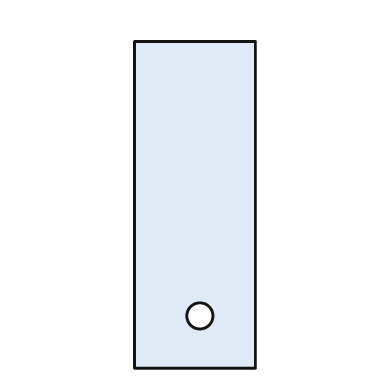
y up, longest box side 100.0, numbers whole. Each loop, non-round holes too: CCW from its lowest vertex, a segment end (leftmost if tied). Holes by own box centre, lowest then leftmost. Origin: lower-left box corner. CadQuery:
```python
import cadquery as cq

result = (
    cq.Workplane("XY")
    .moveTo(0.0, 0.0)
    .lineTo(37.0, 0.0)
    .lineTo(37.0, 100.0)
    .lineTo(0.0, 100.0)
    .close()
    .moveTo(20.0, 16.0)
    .circle(4.0)
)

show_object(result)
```